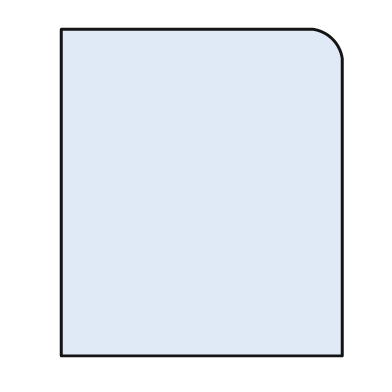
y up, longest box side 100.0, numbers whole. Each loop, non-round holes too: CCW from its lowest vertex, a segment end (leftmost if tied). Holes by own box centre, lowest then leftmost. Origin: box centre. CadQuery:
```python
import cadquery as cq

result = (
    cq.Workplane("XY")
    .moveTo(-43.0, -50.0)
    .lineTo(43.0, -50.0)
    .lineTo(43.0, 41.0)
    .threePointArc((40.0, 47.0), (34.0, 50.0))
    .lineTo(-43.0, 50.0)
    .close()
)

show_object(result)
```